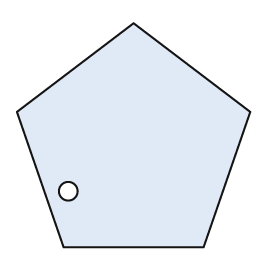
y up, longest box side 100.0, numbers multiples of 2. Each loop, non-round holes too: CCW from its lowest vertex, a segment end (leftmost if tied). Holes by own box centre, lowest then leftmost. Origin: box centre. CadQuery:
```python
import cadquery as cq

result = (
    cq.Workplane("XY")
    .moveTo(-30.0, -48.0)
    .lineTo(30.0, -48.0)
    .lineTo(50.0, 10.0)
    .lineTo(0.0, 48.0)
    .lineTo(-50.0, 10.0)
    .close()
    .moveTo(-28.0, -24.0)
    .circle(4.0)
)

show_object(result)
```